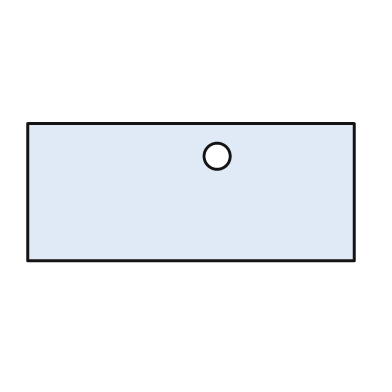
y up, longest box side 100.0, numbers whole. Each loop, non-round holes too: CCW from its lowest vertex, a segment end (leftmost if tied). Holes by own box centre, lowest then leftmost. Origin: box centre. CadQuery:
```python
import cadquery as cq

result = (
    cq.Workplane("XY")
    .moveTo(-50.0, -21.0)
    .lineTo(50.0, -21.0)
    .lineTo(50.0, 21.0)
    .lineTo(-50.0, 21.0)
    .close()
    .moveTo(8.0, 11.0)
    .circle(4.0)
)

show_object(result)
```